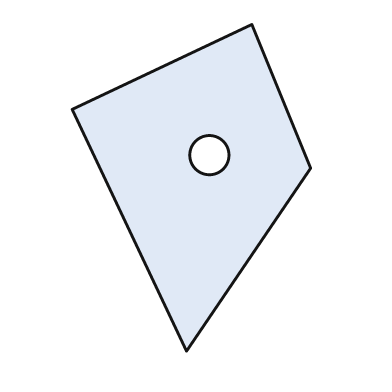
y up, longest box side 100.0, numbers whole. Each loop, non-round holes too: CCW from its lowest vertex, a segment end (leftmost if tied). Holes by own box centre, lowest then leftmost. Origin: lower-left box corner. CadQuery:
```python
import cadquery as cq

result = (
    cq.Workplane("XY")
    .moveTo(35.0, 0.0)
    .lineTo(73.0, 56.0)
    .lineTo(55.0, 100.0)
    .lineTo(0.0, 74.0)
    .close()
    .moveTo(42.0, 60.0)
    .circle(6.0)
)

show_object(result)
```